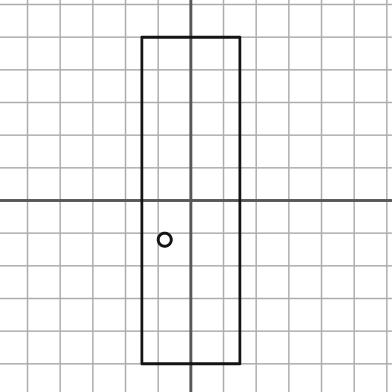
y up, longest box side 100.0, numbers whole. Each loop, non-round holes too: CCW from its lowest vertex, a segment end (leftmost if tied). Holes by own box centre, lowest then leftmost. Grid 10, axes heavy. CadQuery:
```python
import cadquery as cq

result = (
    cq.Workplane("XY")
    .moveTo(-15.0, -50.0)
    .lineTo(15.0, -50.0)
    .lineTo(15.0, 50.0)
    .lineTo(-15.0, 50.0)
    .close()
    .moveTo(-8.0, -12.0)
    .circle(2.0)
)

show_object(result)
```